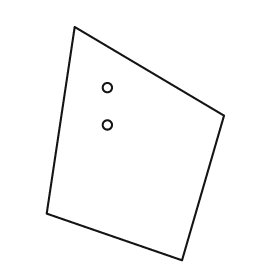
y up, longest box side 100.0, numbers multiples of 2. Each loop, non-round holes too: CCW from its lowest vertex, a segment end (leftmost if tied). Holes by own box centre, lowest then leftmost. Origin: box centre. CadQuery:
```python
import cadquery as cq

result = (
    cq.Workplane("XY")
    .moveTo(20.0, -50.0)
    .lineTo(38.0, 12.0)
    .lineTo(-26.0, 50.0)
    .lineTo(-38.0, -30.0)
    .close()
    .moveTo(-12.0, 8.0)
    .circle(2.0)
    .moveTo(-12.0, 24.0)
    .circle(2.0)
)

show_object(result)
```